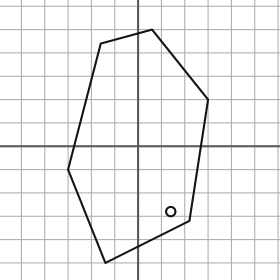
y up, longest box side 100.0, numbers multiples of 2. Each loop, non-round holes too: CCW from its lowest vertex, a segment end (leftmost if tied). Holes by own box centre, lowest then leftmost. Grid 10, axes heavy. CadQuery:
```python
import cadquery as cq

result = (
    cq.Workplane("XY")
    .moveTo(-14.0, -50.0)
    .lineTo(22.0, -32.0)
    .lineTo(30.0, 20.0)
    .lineTo(6.0, 50.0)
    .lineTo(-16.0, 44.0)
    .lineTo(-30.0, -10.0)
    .close()
    .moveTo(14.0, -28.0)
    .circle(2.0)
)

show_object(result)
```